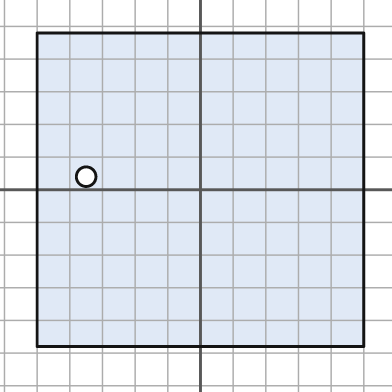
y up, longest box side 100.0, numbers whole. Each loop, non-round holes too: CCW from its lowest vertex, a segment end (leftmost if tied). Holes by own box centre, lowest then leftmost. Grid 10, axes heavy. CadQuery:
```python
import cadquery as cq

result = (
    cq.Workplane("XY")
    .moveTo(-50.0, -48.0)
    .lineTo(50.0, -48.0)
    .lineTo(50.0, 48.0)
    .lineTo(-50.0, 48.0)
    .close()
    .moveTo(-35.0, 4.0)
    .circle(3.0)
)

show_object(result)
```